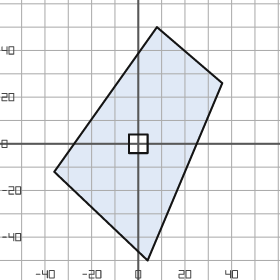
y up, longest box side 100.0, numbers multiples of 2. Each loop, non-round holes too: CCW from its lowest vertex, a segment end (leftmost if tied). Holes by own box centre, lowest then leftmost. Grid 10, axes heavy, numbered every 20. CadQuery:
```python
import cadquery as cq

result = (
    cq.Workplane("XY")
    .moveTo(4.0, -50.0)
    .lineTo(36.0, 26.0)
    .lineTo(8.0, 50.0)
    .lineTo(-36.0, -12.0)
    .close()
    .moveTo(-4.0, -4.0)
    .lineTo(4.0, -4.0)
    .lineTo(4.0, 4.0)
    .lineTo(-4.0, 4.0)
    .close()
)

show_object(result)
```